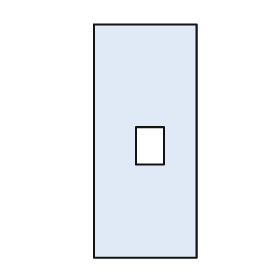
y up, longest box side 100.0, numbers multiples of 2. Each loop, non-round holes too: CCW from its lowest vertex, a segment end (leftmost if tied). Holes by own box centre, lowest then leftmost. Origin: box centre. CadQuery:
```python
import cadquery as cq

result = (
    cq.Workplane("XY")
    .moveTo(-22.0, -50.0)
    .lineTo(22.0, -50.0)
    .lineTo(22.0, 50.0)
    .lineTo(-22.0, 50.0)
    .close()
    .moveTo(-4.0, -10.0)
    .lineTo(8.0, -10.0)
    .lineTo(8.0, 6.0)
    .lineTo(-4.0, 6.0)
    .close()
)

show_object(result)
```